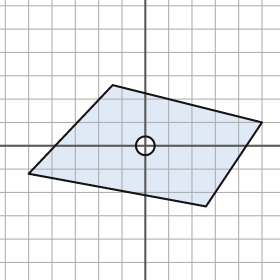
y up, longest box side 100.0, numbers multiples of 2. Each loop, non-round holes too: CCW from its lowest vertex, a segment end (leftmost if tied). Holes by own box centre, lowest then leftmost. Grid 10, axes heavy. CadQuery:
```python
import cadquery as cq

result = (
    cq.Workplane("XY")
    .moveTo(26.0, -26.0)
    .lineTo(50.0, 10.0)
    .lineTo(-14.0, 26.0)
    .lineTo(-50.0, -12.0)
    .close()
    .moveTo(0.0, 0.0)
    .circle(4.0)
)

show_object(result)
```